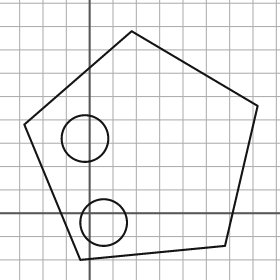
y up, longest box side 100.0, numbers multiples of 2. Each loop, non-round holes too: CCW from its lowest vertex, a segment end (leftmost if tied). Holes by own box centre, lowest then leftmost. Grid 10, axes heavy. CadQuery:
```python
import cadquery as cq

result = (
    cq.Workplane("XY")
    .moveTo(-4.0, -20.0)
    .lineTo(58.0, -14.0)
    .lineTo(72.0, 46.0)
    .lineTo(18.0, 78.0)
    .lineTo(-28.0, 38.0)
    .close()
    .moveTo(6.0, -4.0)
    .circle(10.0)
    .moveTo(-2.0, 32.0)
    .circle(10.0)
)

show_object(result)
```